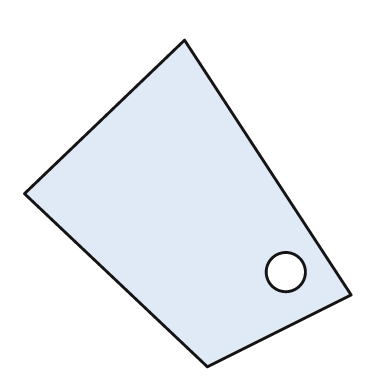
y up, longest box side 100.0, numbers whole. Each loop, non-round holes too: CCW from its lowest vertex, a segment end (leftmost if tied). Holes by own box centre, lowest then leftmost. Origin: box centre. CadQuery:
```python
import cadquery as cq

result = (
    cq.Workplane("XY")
    .moveTo(6.0, -50.0)
    .lineTo(50.0, -28.0)
    .lineTo(-1.0, 50.0)
    .lineTo(-50.0, 3.0)
    .close()
    .moveTo(30.0, -21.0)
    .circle(6.0)
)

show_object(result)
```